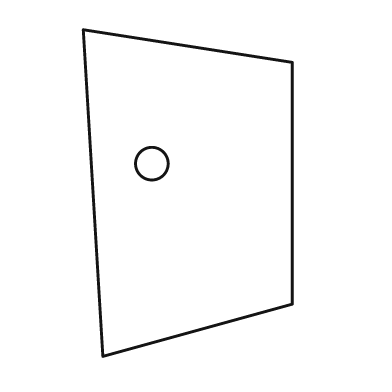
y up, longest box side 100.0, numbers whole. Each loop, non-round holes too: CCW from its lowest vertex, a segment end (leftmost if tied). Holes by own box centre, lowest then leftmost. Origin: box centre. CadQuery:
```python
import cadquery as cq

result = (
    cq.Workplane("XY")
    .moveTo(-26.0, -50.0)
    .lineTo(32.0, -34.0)
    .lineTo(32.0, 40.0)
    .lineTo(-32.0, 50.0)
    .close()
    .moveTo(-11.0, 9.0)
    .circle(5.0)
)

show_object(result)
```